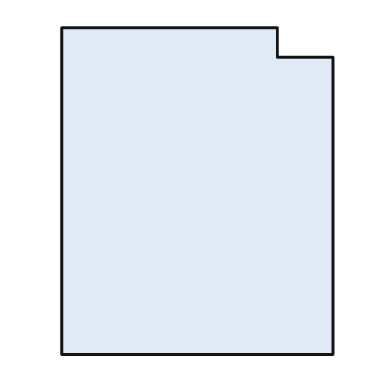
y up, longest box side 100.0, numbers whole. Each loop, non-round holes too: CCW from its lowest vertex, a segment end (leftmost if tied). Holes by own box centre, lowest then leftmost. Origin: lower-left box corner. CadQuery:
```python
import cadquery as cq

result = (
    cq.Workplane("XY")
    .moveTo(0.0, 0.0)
    .lineTo(83.0, 0.0)
    .lineTo(83.0, 91.0)
    .lineTo(66.0, 91.0)
    .lineTo(66.0, 100.0)
    .lineTo(0.0, 100.0)
    .close()
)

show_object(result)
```